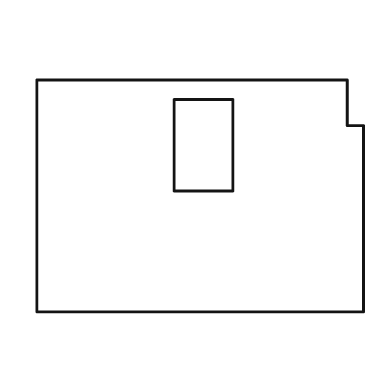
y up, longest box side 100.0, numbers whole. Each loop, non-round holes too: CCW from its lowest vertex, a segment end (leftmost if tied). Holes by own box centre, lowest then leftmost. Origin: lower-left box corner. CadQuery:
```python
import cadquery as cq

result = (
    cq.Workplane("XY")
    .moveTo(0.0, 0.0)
    .lineTo(100.0, 0.0)
    .lineTo(100.0, 57.0)
    .lineTo(95.0, 57.0)
    .lineTo(95.0, 71.0)
    .lineTo(0.0, 71.0)
    .close()
    .moveTo(42.0, 37.0)
    .lineTo(60.0, 37.0)
    .lineTo(60.0, 65.0)
    .lineTo(42.0, 65.0)
    .close()
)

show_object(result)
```